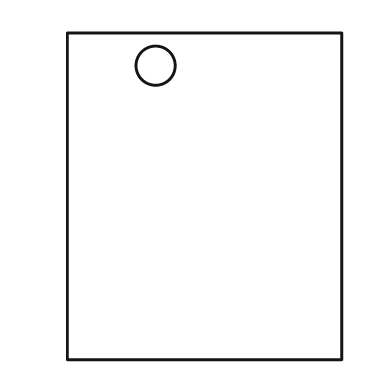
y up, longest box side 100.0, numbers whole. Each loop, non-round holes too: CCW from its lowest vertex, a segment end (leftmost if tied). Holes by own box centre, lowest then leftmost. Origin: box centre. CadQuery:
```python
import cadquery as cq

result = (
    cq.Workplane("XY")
    .moveTo(-42.0, -50.0)
    .lineTo(42.0, -50.0)
    .lineTo(42.0, 50.0)
    .lineTo(-42.0, 50.0)
    .close()
    .moveTo(-15.0, 40.0)
    .circle(6.0)
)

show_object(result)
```